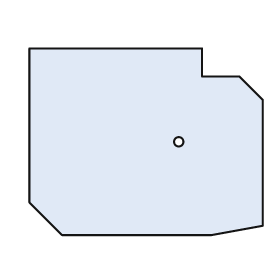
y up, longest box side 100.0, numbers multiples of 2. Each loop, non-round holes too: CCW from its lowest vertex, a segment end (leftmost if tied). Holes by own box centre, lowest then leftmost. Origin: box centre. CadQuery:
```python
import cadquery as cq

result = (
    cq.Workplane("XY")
    .moveTo(-36.0, -40.0)
    .lineTo(28.0, -40.0)
    .lineTo(50.0, -36.0)
    .lineTo(50.0, 18.0)
    .lineTo(40.0, 28.0)
    .lineTo(24.0, 28.0)
    .lineTo(24.0, 40.0)
    .lineTo(-50.0, 40.0)
    .lineTo(-50.0, -26.0)
    .close()
    .moveTo(14.0, 0.0)
    .circle(2.0)
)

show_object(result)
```